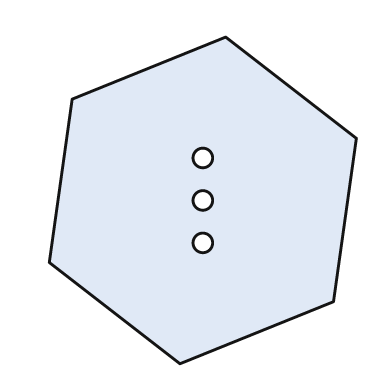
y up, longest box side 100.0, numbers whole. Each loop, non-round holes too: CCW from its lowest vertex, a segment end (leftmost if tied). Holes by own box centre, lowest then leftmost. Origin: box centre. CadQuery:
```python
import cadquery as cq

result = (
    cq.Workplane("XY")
    .moveTo(-7.0, -50.0)
    .lineTo(40.0, -31.0)
    .lineTo(47.0, 19.0)
    .lineTo(7.0, 50.0)
    .lineTo(-40.0, 31.0)
    .lineTo(-47.0, -19.0)
    .close()
    .moveTo(0.0, -13.0)
    .circle(3.0)
    .moveTo(0.0, 0.0)
    .circle(3.0)
    .moveTo(0.0, 13.0)
    .circle(3.0)
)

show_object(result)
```